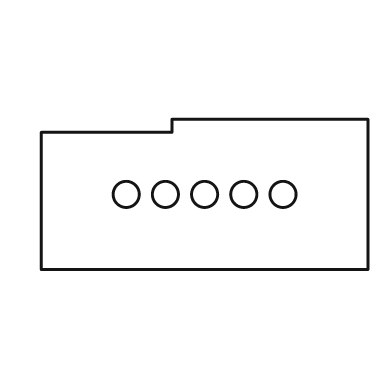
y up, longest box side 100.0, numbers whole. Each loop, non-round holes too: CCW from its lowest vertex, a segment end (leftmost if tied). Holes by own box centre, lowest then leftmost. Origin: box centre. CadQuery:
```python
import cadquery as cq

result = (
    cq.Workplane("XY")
    .moveTo(-50.0, -23.0)
    .lineTo(50.0, -23.0)
    .lineTo(50.0, 23.0)
    .lineTo(-10.0, 23.0)
    .lineTo(-10.0, 19.0)
    .lineTo(-50.0, 19.0)
    .close()
    .moveTo(-24.0, 0.0)
    .circle(4.0)
    .moveTo(-12.0, 0.0)
    .circle(4.0)
    .moveTo(0.0, 0.0)
    .circle(4.0)
    .moveTo(12.0, 0.0)
    .circle(4.0)
    .moveTo(24.0, 0.0)
    .circle(4.0)
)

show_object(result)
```